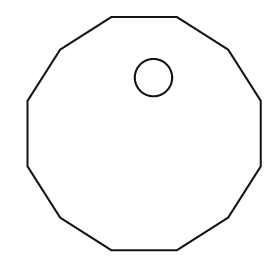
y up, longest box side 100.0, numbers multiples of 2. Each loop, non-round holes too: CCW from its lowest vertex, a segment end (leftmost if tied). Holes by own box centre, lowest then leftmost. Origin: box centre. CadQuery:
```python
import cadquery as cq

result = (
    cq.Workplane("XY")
    .moveTo(-14.0, -50.0)
    .lineTo(14.0, -50.0)
    .lineTo(36.0, -36.0)
    .lineTo(50.0, -14.0)
    .lineTo(50.0, 14.0)
    .lineTo(36.0, 36.0)
    .lineTo(14.0, 50.0)
    .lineTo(-14.0, 50.0)
    .lineTo(-36.0, 36.0)
    .lineTo(-50.0, 14.0)
    .lineTo(-50.0, -14.0)
    .lineTo(-36.0, -36.0)
    .close()
    .moveTo(4.0, 24.0)
    .circle(8.0)
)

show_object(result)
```